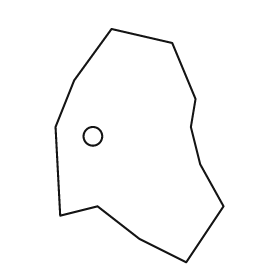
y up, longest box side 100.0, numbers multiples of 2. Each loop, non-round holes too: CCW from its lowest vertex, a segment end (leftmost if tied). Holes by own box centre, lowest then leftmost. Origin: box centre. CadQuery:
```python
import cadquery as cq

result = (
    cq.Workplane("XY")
    .moveTo(20.0, -50.0)
    .lineTo(36.0, -26.0)
    .lineTo(26.0, -8.0)
    .lineTo(22.0, 8.0)
    .lineTo(24.0, 20.0)
    .lineTo(14.0, 44.0)
    .lineTo(-12.0, 50.0)
    .lineTo(-28.0, 28.0)
    .lineTo(-36.0, 8.0)
    .lineTo(-34.0, -30.0)
    .lineTo(-18.0, -26.0)
    .lineTo(0.0, -40.0)
    .close()
    .moveTo(-20.0, 4.0)
    .circle(4.0)
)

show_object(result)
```